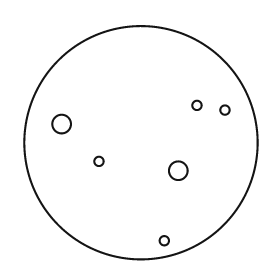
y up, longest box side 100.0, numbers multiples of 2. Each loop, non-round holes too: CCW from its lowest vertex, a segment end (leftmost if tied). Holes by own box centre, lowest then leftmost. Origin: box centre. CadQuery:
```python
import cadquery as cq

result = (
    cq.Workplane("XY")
    .moveTo(0.0, 0.0)
    .circle(50.0)
    .moveTo(10.0, -42.0)
    .circle(2.0)
    .moveTo(16.0, -12.0)
    .circle(4.0)
    .moveTo(-18.0, -8.0)
    .circle(2.0)
    .moveTo(-34.0, 8.0)
    .circle(4.0)
    .moveTo(36.0, 14.0)
    .circle(2.0)
    .moveTo(24.0, 16.0)
    .circle(2.0)
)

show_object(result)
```